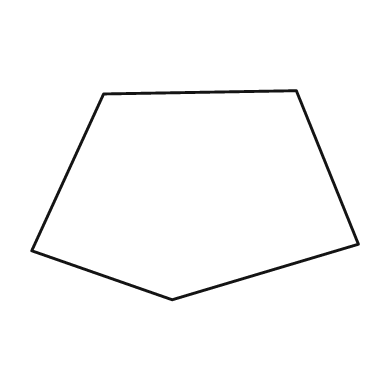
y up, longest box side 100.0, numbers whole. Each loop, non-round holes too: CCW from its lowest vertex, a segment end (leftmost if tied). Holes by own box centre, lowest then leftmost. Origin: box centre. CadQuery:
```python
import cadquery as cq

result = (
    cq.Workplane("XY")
    .moveTo(-7.0, -32.0)
    .lineTo(50.0, -15.0)
    .lineTo(31.0, 32.0)
    .lineTo(-28.0, 31.0)
    .lineTo(-50.0, -17.0)
    .close()
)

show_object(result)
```